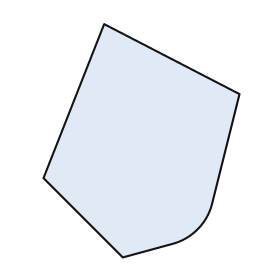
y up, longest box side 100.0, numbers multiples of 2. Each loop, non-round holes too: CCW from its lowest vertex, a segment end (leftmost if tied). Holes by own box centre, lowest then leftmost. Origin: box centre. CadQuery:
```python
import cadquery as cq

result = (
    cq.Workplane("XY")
    .moveTo(-8.0, -50.0)
    .lineTo(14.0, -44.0)
    .threePointArc((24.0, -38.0), (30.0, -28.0))
    .lineTo(42.0, 20.0)
    .lineTo(-16.0, 50.0)
    .lineTo(-42.0, -16.0)
    .close()
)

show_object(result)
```